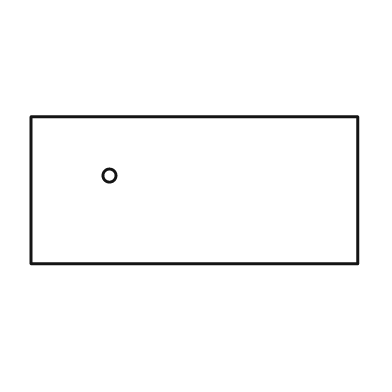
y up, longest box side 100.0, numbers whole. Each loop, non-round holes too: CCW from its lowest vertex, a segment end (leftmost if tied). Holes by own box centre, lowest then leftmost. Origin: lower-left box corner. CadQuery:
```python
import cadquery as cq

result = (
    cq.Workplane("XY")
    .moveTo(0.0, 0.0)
    .lineTo(100.0, 0.0)
    .lineTo(100.0, 45.0)
    .lineTo(0.0, 45.0)
    .close()
    .moveTo(24.0, 27.0)
    .circle(2.0)
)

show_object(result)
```